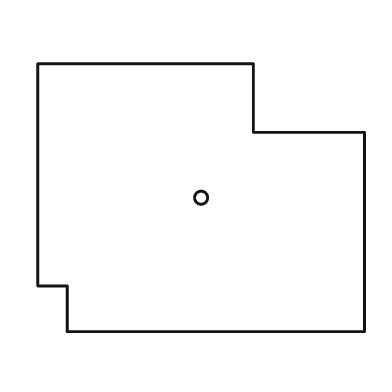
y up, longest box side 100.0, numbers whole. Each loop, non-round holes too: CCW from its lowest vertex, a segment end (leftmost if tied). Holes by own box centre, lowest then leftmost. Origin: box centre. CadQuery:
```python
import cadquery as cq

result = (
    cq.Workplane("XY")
    .moveTo(-41.0, -41.0)
    .lineTo(50.0, -41.0)
    .lineTo(50.0, 20.0)
    .lineTo(16.0, 20.0)
    .lineTo(16.0, 41.0)
    .lineTo(-50.0, 41.0)
    .lineTo(-50.0, -27.0)
    .lineTo(-41.0, -27.0)
    .close()
    .moveTo(0.0, 0.0)
    .circle(2.0)
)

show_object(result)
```